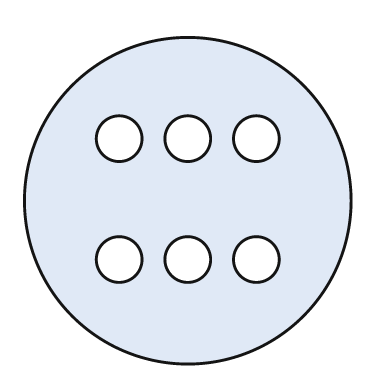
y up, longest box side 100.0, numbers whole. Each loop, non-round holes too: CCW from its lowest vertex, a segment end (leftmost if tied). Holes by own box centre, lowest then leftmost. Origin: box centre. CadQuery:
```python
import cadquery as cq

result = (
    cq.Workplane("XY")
    .moveTo(0.0, 0.0)
    .circle(50.0)
    .moveTo(-21.0, -18.0)
    .circle(7.0)
    .moveTo(0.0, -18.0)
    .circle(7.0)
    .moveTo(21.0, -18.0)
    .circle(7.0)
    .moveTo(-21.0, 19.0)
    .circle(7.0)
    .moveTo(0.0, 19.0)
    .circle(7.0)
    .moveTo(21.0, 19.0)
    .circle(7.0)
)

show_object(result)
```